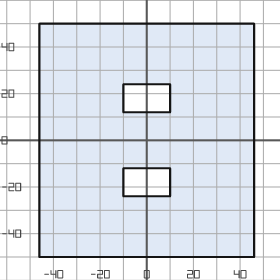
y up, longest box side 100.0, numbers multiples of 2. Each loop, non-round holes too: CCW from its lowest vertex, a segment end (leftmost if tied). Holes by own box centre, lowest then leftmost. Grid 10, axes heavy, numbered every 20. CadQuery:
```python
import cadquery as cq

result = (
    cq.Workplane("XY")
    .moveTo(-46.0, -50.0)
    .lineTo(46.0, -50.0)
    .lineTo(46.0, 50.0)
    .lineTo(-46.0, 50.0)
    .close()
    .moveTo(-10.0, -24.0)
    .lineTo(10.0, -24.0)
    .lineTo(10.0, -12.0)
    .lineTo(-10.0, -12.0)
    .close()
    .moveTo(-10.0, 12.0)
    .lineTo(10.0, 12.0)
    .lineTo(10.0, 24.0)
    .lineTo(-10.0, 24.0)
    .close()
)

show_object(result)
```